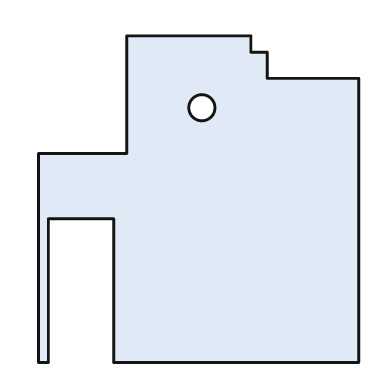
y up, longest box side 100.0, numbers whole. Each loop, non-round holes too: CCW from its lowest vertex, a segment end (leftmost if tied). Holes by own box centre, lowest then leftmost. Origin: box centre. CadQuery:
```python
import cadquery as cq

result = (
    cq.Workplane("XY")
    .moveTo(-49.0, -50.0)
    .lineTo(-46.0, -50.0)
    .lineTo(-46.0, -6.0)
    .lineTo(-26.0, -6.0)
    .lineTo(-26.0, -50.0)
    .lineTo(49.0, -50.0)
    .lineTo(49.0, 37.0)
    .lineTo(21.0, 37.0)
    .lineTo(21.0, 45.0)
    .lineTo(16.0, 45.0)
    .lineTo(16.0, 50.0)
    .lineTo(-22.0, 50.0)
    .lineTo(-22.0, 14.0)
    .lineTo(-49.0, 14.0)
    .close()
    .moveTo(1.0, 28.0)
    .circle(4.0)
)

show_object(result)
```